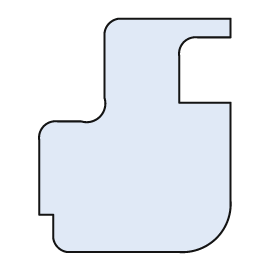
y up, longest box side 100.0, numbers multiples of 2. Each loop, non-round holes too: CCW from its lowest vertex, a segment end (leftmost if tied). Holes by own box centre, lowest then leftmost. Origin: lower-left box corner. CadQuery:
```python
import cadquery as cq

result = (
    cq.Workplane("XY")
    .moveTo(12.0, 0.0)
    .lineTo(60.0, 0.0)
    .threePointArc((76.0, 6.0), (82.0, 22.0))
    .lineTo(82.0, 64.0)
    .lineTo(60.0, 64.0)
    .lineTo(60.0, 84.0)
    .threePointArc((62.0, 90.0), (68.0, 92.0))
    .lineTo(82.0, 92.0)
    .lineTo(82.0, 100.0)
    .lineTo(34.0, 100.0)
    .threePointArc((30.0, 98.0), (28.0, 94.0))
    .lineTo(28.0, 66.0)
    .threePointArc((26.0, 58.0), (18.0, 56.0))
    .lineTo(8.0, 56.0)
    .threePointArc((2.0, 54.0), (0.0, 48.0))
    .lineTo(0.0, 16.0)
    .lineTo(6.0, 16.0)
    .lineTo(6.0, 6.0)
    .threePointArc((8.0, 2.0), (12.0, 0.0))
    .close()
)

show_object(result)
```